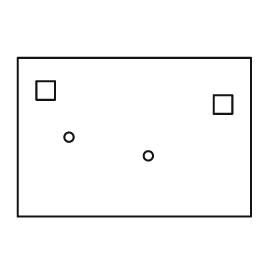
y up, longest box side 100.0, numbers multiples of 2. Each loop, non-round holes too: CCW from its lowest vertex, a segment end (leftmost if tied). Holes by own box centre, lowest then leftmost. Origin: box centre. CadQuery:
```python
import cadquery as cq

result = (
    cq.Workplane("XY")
    .moveTo(-50.0, -34.0)
    .lineTo(50.0, -34.0)
    .lineTo(50.0, 34.0)
    .lineTo(-50.0, 34.0)
    .close()
    .moveTo(6.0, -8.0)
    .circle(2.0)
    .moveTo(-28.0, 0.0)
    .circle(2.0)
    .moveTo(34.0, 10.0)
    .lineTo(42.0, 10.0)
    .lineTo(42.0, 18.0)
    .lineTo(34.0, 18.0)
    .close()
    .moveTo(-42.0, 16.0)
    .lineTo(-34.0, 16.0)
    .lineTo(-34.0, 24.0)
    .lineTo(-42.0, 24.0)
    .close()
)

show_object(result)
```